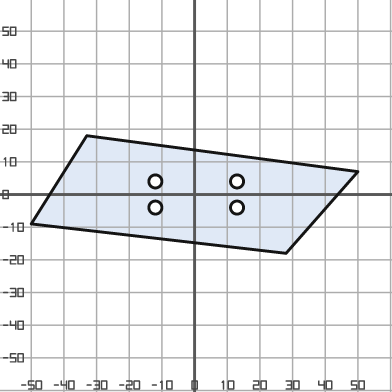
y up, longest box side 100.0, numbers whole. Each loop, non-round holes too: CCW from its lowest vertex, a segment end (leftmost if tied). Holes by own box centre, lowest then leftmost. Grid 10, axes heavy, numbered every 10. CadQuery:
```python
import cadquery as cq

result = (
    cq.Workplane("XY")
    .moveTo(28.0, -18.0)
    .lineTo(50.0, 7.0)
    .lineTo(-33.0, 18.0)
    .lineTo(-50.0, -9.0)
    .close()
    .moveTo(-12.0, -4.0)
    .circle(2.0)
    .moveTo(13.0, -4.0)
    .circle(2.0)
    .moveTo(-12.0, 4.0)
    .circle(2.0)
    .moveTo(13.0, 4.0)
    .circle(2.0)
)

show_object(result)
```